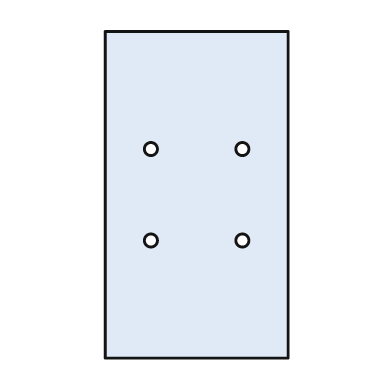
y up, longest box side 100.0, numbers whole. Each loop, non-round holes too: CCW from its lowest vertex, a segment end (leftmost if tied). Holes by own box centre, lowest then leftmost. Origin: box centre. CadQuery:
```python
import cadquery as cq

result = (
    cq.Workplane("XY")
    .moveTo(-28.0, -50.0)
    .lineTo(28.0, -50.0)
    .lineTo(28.0, 50.0)
    .lineTo(-28.0, 50.0)
    .close()
    .moveTo(-14.0, -14.0)
    .circle(2.0)
    .moveTo(14.0, -14.0)
    .circle(2.0)
    .moveTo(-14.0, 14.0)
    .circle(2.0)
    .moveTo(14.0, 14.0)
    .circle(2.0)
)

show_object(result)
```